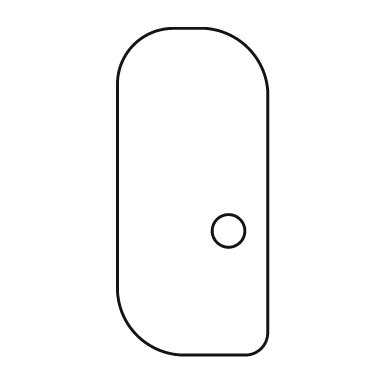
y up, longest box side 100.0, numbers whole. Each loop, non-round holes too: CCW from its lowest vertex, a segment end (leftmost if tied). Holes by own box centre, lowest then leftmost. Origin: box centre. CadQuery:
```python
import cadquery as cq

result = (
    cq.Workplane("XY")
    .moveTo(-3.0, -50.0)
    .lineTo(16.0, -50.0)
    .threePointArc((21.0, -48.0), (23.0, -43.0))
    .lineTo(23.0, 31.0)
    .threePointArc((17.0, 44.0), (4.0, 50.0))
    .lineTo(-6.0, 50.0)
    .threePointArc((-18.0, 45.0), (-23.0, 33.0))
    .lineTo(-23.0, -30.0)
    .threePointArc((-17.0, -44.0), (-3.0, -50.0))
    .close()
    .moveTo(11.0, -12.0)
    .circle(5.0)
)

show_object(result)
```